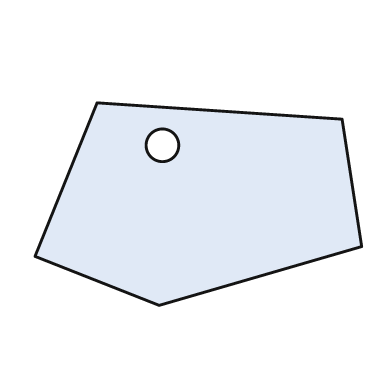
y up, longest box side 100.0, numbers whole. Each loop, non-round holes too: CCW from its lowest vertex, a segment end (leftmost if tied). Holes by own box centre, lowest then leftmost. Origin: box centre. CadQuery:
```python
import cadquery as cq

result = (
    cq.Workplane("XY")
    .moveTo(-12.0, -31.0)
    .lineTo(50.0, -13.0)
    .lineTo(44.0, 26.0)
    .lineTo(-31.0, 31.0)
    .lineTo(-50.0, -16.0)
    .close()
    .moveTo(-11.0, 18.0)
    .circle(5.0)
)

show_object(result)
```